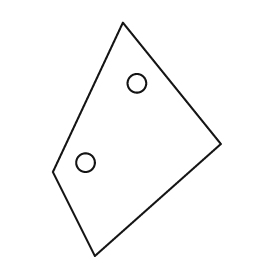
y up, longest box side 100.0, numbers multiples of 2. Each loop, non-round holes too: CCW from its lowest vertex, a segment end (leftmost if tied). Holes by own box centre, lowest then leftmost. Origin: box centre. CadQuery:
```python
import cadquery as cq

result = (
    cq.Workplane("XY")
    .moveTo(-18.0, -50.0)
    .lineTo(36.0, -2.0)
    .lineTo(-6.0, 50.0)
    .lineTo(-36.0, -14.0)
    .close()
    .moveTo(-22.0, -10.0)
    .circle(4.0)
    .moveTo(0.0, 24.0)
    .circle(4.0)
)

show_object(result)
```